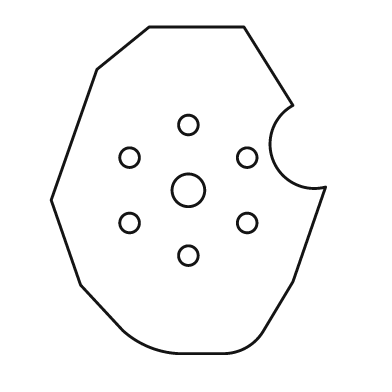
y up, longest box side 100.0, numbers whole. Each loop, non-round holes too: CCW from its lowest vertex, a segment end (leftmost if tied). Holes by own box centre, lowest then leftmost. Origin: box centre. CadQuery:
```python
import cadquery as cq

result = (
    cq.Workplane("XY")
    .moveTo(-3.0, -50.0)
    .lineTo(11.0, -50.0)
    .threePointArc((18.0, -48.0), (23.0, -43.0))
    .lineTo(32.0, -28.0)
    .lineTo(42.0, 1.0)
    .threePointArc((26.0, 9.0), (32.0, 26.0))
    .lineTo(17.0, 50.0)
    .lineTo(-12.0, 50.0)
    .lineTo(-28.0, 37.0)
    .lineTo(-42.0, -3.0)
    .lineTo(-33.0, -29.0)
    .lineTo(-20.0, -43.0)
    .threePointArc((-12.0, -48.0), (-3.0, -50.0))
    .close()
    .moveTo(0.0, -20.0)
    .circle(3.0)
    .moveTo(-18.0, -10.0)
    .circle(3.0)
    .moveTo(18.0, -10.0)
    .circle(3.0)
    .moveTo(0.0, 0.0)
    .circle(5.0)
    .moveTo(-18.0, 10.0)
    .circle(3.0)
    .moveTo(18.0, 10.0)
    .circle(3.0)
    .moveTo(0.0, 20.0)
    .circle(3.0)
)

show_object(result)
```